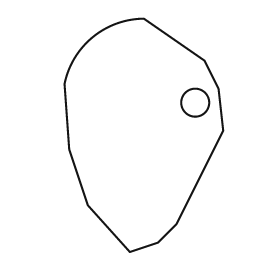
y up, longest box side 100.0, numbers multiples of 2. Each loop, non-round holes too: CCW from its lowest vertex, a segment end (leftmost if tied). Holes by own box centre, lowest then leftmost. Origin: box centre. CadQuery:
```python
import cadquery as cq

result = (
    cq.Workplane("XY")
    .moveTo(-6.0, -50.0)
    .lineTo(6.0, -46.0)
    .lineTo(14.0, -38.0)
    .lineTo(34.0, 2.0)
    .lineTo(32.0, 20.0)
    .lineTo(26.0, 32.0)
    .lineTo(0.0, 50.0)
    .threePointArc((-22.0, 42.0), (-34.0, 22.0))
    .lineTo(-32.0, -6.0)
    .lineTo(-24.0, -30.0)
    .close()
    .moveTo(22.0, 14.0)
    .circle(6.0)
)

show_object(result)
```